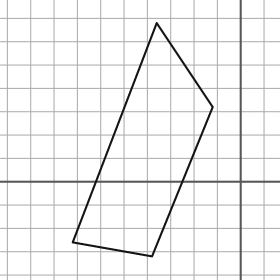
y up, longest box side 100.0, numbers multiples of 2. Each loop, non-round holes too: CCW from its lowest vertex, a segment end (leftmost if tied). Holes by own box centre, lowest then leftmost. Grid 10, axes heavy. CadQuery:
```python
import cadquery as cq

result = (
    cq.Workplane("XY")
    .moveTo(-38.0, -32.0)
    .lineTo(-12.0, 32.0)
    .lineTo(-36.0, 68.0)
    .lineTo(-72.0, -26.0)
    .close()
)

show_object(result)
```